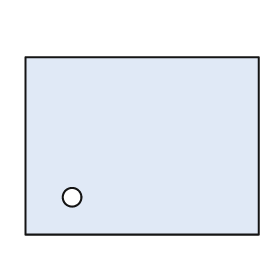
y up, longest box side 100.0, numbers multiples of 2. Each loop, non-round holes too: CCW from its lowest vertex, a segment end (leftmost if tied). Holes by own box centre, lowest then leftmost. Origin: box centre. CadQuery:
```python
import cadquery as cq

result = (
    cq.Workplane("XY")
    .moveTo(-50.0, -38.0)
    .lineTo(50.0, -38.0)
    .lineTo(50.0, 38.0)
    .lineTo(-50.0, 38.0)
    .close()
    .moveTo(-30.0, -22.0)
    .circle(4.0)
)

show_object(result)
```